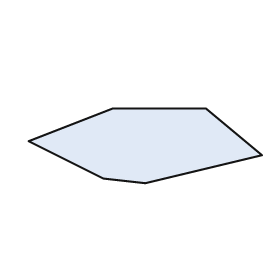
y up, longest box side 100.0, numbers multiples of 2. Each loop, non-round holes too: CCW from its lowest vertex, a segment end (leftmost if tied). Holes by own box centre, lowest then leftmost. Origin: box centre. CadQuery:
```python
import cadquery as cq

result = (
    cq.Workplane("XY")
    .moveTo(0.0, -16.0)
    .lineTo(50.0, -4.0)
    .lineTo(26.0, 16.0)
    .lineTo(-14.0, 16.0)
    .lineTo(-50.0, 2.0)
    .lineTo(-18.0, -14.0)
    .close()
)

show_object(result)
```